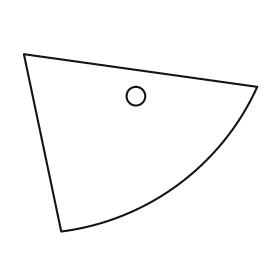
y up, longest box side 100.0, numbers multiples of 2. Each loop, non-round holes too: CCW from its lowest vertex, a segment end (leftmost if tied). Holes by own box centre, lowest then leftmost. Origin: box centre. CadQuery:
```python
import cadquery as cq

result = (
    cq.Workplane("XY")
    .moveTo(-34.0, -38.0)
    .threePointArc((16.0, -18.0), (50.0, 24.0))
    .lineTo(-50.0, 38.0)
    .close()
    .moveTo(-2.0, 20.0)
    .circle(4.0)
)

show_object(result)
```